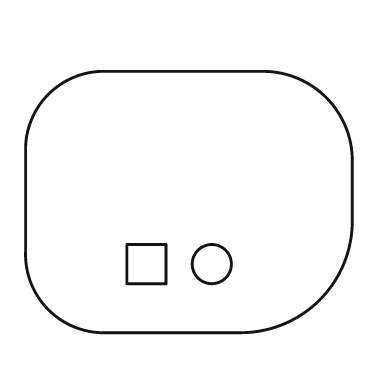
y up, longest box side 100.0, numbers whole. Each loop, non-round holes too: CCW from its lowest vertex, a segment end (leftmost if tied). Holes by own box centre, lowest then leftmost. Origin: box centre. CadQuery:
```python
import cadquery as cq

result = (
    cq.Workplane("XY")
    .moveTo(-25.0, -40.0)
    .lineTo(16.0, -40.0)
    .threePointArc((40.0, -30.0), (50.0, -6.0))
    .lineTo(50.0, 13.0)
    .threePointArc((42.0, 32.0), (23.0, 40.0))
    .lineTo(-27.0, 40.0)
    .threePointArc((-43.0, 33.0), (-50.0, 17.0))
    .lineTo(-50.0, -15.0)
    .threePointArc((-43.0, -33.0), (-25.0, -40.0))
    .close()
    .moveTo(-19.0, -25.0)
    .lineTo(-7.0, -25.0)
    .lineTo(-7.0, -13.0)
    .lineTo(-19.0, -13.0)
    .close()
    .moveTo(7.0, -19.0)
    .circle(6.0)
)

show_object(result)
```